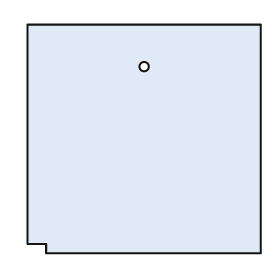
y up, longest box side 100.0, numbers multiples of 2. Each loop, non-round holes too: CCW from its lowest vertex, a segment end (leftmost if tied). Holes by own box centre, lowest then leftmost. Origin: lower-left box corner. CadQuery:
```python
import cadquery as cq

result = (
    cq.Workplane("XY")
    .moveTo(8.0, 0.0)
    .lineTo(100.0, 0.0)
    .lineTo(100.0, 98.0)
    .lineTo(0.0, 98.0)
    .lineTo(0.0, 4.0)
    .lineTo(8.0, 4.0)
    .close()
    .moveTo(50.0, 80.0)
    .circle(2.0)
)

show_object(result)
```